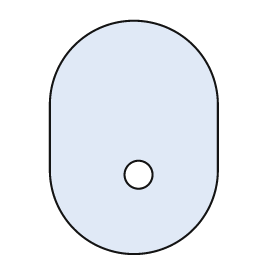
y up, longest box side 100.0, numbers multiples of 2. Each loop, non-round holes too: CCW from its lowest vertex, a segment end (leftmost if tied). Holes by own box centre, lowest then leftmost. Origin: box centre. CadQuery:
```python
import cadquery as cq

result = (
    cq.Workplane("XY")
    .moveTo(-36.0, -14.0)
    .threePointArc((0.0, -50.0), (36.0, -14.0))
    .lineTo(36.0, 14.0)
    .threePointArc((0.0, 50.0), (-36.0, 14.0))
    .close()
    .moveTo(2.0, -16.0)
    .circle(6.0)
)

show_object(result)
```